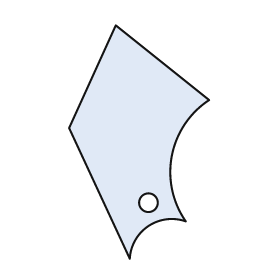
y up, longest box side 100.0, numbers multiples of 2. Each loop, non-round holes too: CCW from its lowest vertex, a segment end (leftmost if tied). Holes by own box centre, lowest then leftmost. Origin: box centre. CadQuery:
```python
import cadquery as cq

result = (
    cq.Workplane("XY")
    .moveTo(-4.0, -50.0)
    .threePointArc((4.0, -36.0), (20.0, -34.0))
    .threePointArc((14.0, -6.0), (30.0, 18.0))
    .lineTo(-10.0, 50.0)
    .lineTo(-30.0, 6.0)
    .close()
    .moveTo(4.0, -26.0)
    .circle(4.0)
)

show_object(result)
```